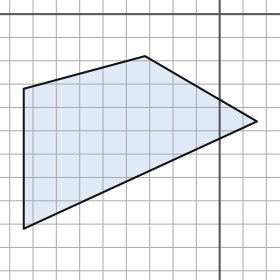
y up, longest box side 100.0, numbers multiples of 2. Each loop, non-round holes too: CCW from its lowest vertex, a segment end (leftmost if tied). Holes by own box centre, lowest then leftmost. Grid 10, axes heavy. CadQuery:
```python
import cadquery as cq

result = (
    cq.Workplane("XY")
    .moveTo(-84.0, -92.0)
    .lineTo(16.0, -46.0)
    .lineTo(-32.0, -18.0)
    .lineTo(-84.0, -32.0)
    .close()
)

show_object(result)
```